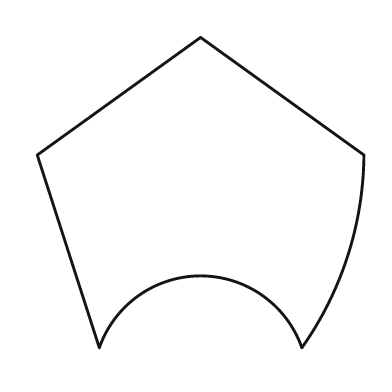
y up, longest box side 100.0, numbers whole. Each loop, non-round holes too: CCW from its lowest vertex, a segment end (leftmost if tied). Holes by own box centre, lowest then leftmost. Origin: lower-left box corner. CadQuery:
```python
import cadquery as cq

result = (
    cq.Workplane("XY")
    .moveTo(19.0, 0.0)
    .threePointArc((50.0, 22.0), (81.0, 0.0))
    .threePointArc((95.0, 28.0), (100.0, 59.0))
    .lineTo(50.0, 95.0)
    .lineTo(0.0, 59.0)
    .close()
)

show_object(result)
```